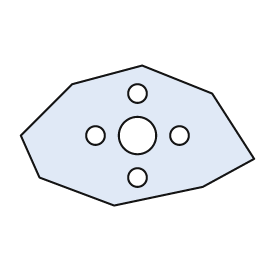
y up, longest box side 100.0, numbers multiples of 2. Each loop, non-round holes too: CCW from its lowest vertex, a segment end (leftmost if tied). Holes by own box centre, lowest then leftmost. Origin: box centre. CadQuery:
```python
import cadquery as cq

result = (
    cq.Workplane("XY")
    .moveTo(-10.0, -30.0)
    .lineTo(28.0, -22.0)
    .lineTo(50.0, -10.0)
    .lineTo(32.0, 18.0)
    .lineTo(2.0, 30.0)
    .lineTo(-28.0, 22.0)
    .lineTo(-50.0, 0.0)
    .lineTo(-42.0, -18.0)
    .close()
    .moveTo(0.0, -18.0)
    .circle(4.0)
    .moveTo(-18.0, 0.0)
    .circle(4.0)
    .moveTo(0.0, 0.0)
    .circle(8.0)
    .moveTo(18.0, 0.0)
    .circle(4.0)
    .moveTo(0.0, 18.0)
    .circle(4.0)
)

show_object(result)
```